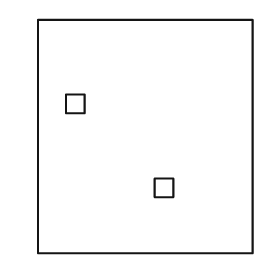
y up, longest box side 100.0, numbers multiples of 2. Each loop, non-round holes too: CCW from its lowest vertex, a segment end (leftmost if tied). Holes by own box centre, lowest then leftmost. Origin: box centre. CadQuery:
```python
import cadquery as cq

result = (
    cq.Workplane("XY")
    .moveTo(-46.0, -50.0)
    .lineTo(46.0, -50.0)
    .lineTo(46.0, 50.0)
    .lineTo(-46.0, 50.0)
    .close()
    .moveTo(4.0, -26.0)
    .lineTo(12.0, -26.0)
    .lineTo(12.0, -18.0)
    .lineTo(4.0, -18.0)
    .close()
    .moveTo(-34.0, 10.0)
    .lineTo(-26.0, 10.0)
    .lineTo(-26.0, 18.0)
    .lineTo(-34.0, 18.0)
    .close()
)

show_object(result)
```